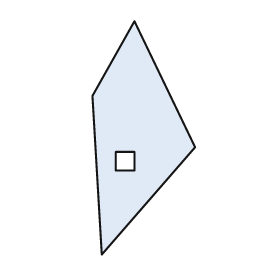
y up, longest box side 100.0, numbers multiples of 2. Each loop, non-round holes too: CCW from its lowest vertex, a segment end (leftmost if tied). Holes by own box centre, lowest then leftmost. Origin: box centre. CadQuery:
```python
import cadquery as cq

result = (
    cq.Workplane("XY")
    .moveTo(-18.0, -50.0)
    .lineTo(22.0, -4.0)
    .lineTo(-4.0, 50.0)
    .lineTo(-22.0, 18.0)
    .close()
    .moveTo(-12.0, -14.0)
    .lineTo(-4.0, -14.0)
    .lineTo(-4.0, -6.0)
    .lineTo(-12.0, -6.0)
    .close()
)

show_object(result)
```